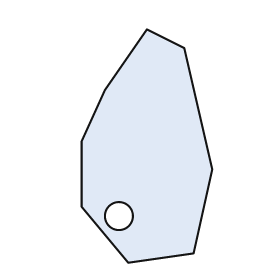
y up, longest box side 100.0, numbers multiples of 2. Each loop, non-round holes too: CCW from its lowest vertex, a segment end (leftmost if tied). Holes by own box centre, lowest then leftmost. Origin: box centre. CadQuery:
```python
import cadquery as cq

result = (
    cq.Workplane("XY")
    .moveTo(-8.0, -50.0)
    .lineTo(20.0, -46.0)
    .lineTo(28.0, -10.0)
    .lineTo(16.0, 42.0)
    .lineTo(0.0, 50.0)
    .lineTo(-18.0, 24.0)
    .lineTo(-28.0, 2.0)
    .lineTo(-28.0, -26.0)
    .close()
    .moveTo(-12.0, -30.0)
    .circle(6.0)
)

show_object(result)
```